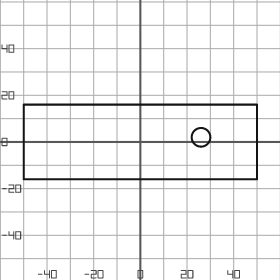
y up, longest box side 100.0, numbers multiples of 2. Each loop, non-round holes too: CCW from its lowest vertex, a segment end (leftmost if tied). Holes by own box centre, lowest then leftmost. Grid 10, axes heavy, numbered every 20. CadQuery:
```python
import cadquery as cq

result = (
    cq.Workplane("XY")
    .moveTo(-50.0, -16.0)
    .lineTo(50.0, -16.0)
    .lineTo(50.0, 16.0)
    .lineTo(-50.0, 16.0)
    .close()
    .moveTo(26.0, 2.0)
    .circle(4.0)
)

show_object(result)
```